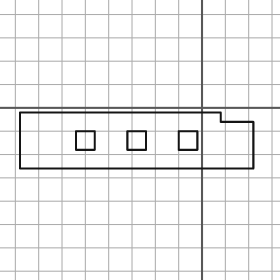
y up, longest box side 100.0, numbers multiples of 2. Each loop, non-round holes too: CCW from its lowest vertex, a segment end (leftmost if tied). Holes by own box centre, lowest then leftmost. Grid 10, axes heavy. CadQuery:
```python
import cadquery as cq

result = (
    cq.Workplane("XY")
    .moveTo(-78.0, -26.0)
    .lineTo(22.0, -26.0)
    .lineTo(22.0, -6.0)
    .lineTo(8.0, -6.0)
    .lineTo(8.0, -2.0)
    .lineTo(-78.0, -2.0)
    .close()
    .moveTo(-54.0, -18.0)
    .lineTo(-46.0, -18.0)
    .lineTo(-46.0, -10.0)
    .lineTo(-54.0, -10.0)
    .close()
    .moveTo(-32.0, -18.0)
    .lineTo(-24.0, -18.0)
    .lineTo(-24.0, -10.0)
    .lineTo(-32.0, -10.0)
    .close()
    .moveTo(-10.0, -18.0)
    .lineTo(-2.0, -18.0)
    .lineTo(-2.0, -10.0)
    .lineTo(-10.0, -10.0)
    .close()
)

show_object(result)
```